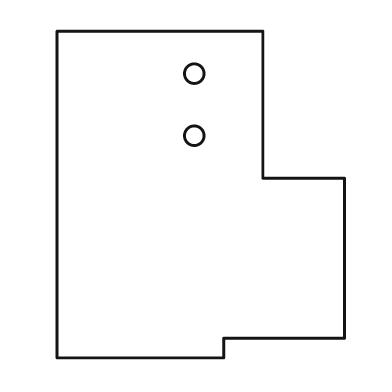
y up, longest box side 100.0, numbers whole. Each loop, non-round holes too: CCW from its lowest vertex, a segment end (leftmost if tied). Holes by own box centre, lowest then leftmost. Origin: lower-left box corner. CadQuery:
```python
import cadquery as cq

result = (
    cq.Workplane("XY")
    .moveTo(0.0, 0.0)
    .lineTo(51.0, 0.0)
    .lineTo(51.0, 6.0)
    .lineTo(88.0, 6.0)
    .lineTo(88.0, 55.0)
    .lineTo(63.0, 55.0)
    .lineTo(63.0, 100.0)
    .lineTo(0.0, 100.0)
    .close()
    .moveTo(42.0, 68.0)
    .circle(3.0)
    .moveTo(42.0, 87.0)
    .circle(3.0)
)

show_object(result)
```